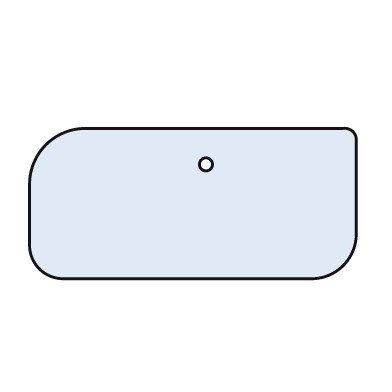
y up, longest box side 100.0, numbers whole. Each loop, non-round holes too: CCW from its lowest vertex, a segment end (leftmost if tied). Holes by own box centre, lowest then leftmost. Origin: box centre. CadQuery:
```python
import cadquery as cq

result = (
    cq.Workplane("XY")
    .moveTo(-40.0, -23.0)
    .lineTo(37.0, -23.0)
    .threePointArc((46.0, -19.0), (50.0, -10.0))
    .lineTo(50.0, 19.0)
    .threePointArc((49.0, 22.0), (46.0, 23.0))
    .lineTo(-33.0, 23.0)
    .threePointArc((-45.0, 18.0), (-50.0, 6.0))
    .lineTo(-50.0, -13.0)
    .threePointArc((-47.0, -20.0), (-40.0, -23.0))
    .close()
    .moveTo(4.0, 12.0)
    .circle(2.0)
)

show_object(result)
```